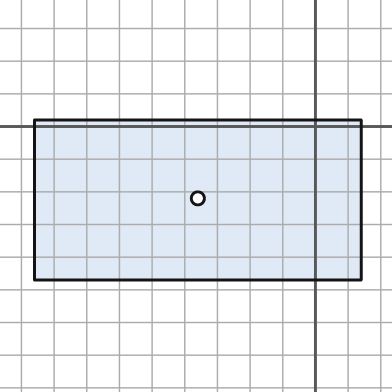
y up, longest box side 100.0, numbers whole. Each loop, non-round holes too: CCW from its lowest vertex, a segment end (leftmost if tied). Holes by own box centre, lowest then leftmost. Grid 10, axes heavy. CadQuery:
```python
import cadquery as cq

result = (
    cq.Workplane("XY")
    .moveTo(-86.0, -47.0)
    .lineTo(14.0, -47.0)
    .lineTo(14.0, 2.0)
    .lineTo(-86.0, 2.0)
    .close()
    .moveTo(-36.0, -22.0)
    .circle(2.0)
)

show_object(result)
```